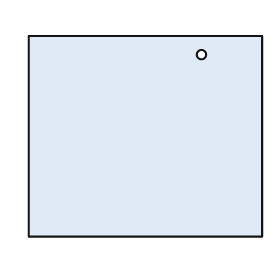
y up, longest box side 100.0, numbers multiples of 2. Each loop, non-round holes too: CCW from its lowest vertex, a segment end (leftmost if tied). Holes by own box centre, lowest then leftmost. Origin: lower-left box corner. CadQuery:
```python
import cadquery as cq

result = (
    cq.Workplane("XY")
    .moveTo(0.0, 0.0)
    .lineTo(100.0, 0.0)
    .lineTo(100.0, 86.0)
    .lineTo(0.0, 86.0)
    .close()
    .moveTo(74.0, 78.0)
    .circle(2.0)
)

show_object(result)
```